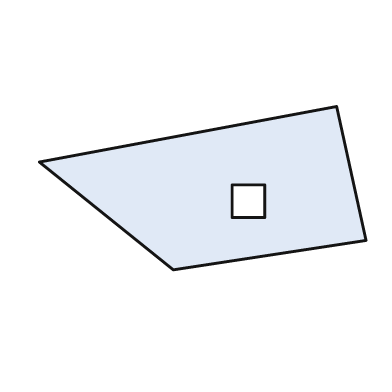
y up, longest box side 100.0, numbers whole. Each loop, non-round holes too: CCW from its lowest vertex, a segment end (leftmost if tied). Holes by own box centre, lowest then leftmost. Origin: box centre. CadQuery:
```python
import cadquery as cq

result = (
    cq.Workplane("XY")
    .moveTo(-9.0, -25.0)
    .lineTo(50.0, -16.0)
    .lineTo(41.0, 25.0)
    .lineTo(-50.0, 8.0)
    .close()
    .moveTo(9.0, -9.0)
    .lineTo(19.0, -9.0)
    .lineTo(19.0, 1.0)
    .lineTo(9.0, 1.0)
    .close()
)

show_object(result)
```